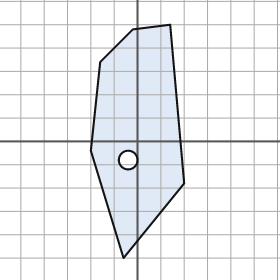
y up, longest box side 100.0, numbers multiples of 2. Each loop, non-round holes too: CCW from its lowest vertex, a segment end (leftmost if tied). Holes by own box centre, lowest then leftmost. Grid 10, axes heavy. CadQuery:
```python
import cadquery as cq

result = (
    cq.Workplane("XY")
    .moveTo(-6.0, -50.0)
    .lineTo(20.0, -18.0)
    .lineTo(14.0, 50.0)
    .lineTo(-2.0, 48.0)
    .lineTo(-16.0, 34.0)
    .lineTo(-20.0, -4.0)
    .close()
    .moveTo(-4.0, -8.0)
    .circle(4.0)
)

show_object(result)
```